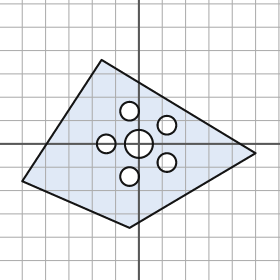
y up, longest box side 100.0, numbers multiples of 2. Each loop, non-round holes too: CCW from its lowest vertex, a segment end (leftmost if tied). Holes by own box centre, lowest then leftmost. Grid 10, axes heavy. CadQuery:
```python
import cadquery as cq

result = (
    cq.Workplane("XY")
    .moveTo(-4.0, -36.0)
    .lineTo(50.0, -4.0)
    .lineTo(-16.0, 36.0)
    .lineTo(-50.0, -16.0)
    .close()
    .moveTo(-4.0, -14.0)
    .circle(4.0)
    .moveTo(12.0, -8.0)
    .circle(4.0)
    .moveTo(-14.0, 0.0)
    .circle(4.0)
    .moveTo(0.0, 0.0)
    .circle(6.0)
    .moveTo(12.0, 8.0)
    .circle(4.0)
    .moveTo(-4.0, 14.0)
    .circle(4.0)
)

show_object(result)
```